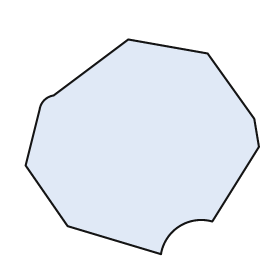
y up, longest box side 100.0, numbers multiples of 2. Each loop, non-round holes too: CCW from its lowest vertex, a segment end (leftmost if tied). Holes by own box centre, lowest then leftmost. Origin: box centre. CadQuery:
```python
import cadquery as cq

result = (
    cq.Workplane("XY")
    .moveTo(8.0, -46.0)
    .threePointArc((16.0, -34.0), (30.0, -32.0))
    .lineTo(50.0, 0.0)
    .lineTo(48.0, 12.0)
    .lineTo(28.0, 40.0)
    .lineTo(-6.0, 46.0)
    .lineTo(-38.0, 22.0)
    .threePointArc((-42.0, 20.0), (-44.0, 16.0))
    .lineTo(-50.0, -8.0)
    .lineTo(-32.0, -34.0)
    .close()
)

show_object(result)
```